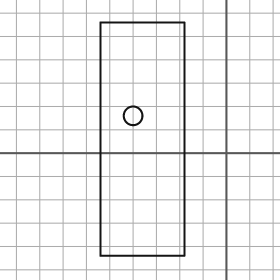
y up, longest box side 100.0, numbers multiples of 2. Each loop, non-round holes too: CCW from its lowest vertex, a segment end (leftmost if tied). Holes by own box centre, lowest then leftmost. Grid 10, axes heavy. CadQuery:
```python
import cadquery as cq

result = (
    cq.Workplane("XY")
    .moveTo(-54.0, -44.0)
    .lineTo(-18.0, -44.0)
    .lineTo(-18.0, 56.0)
    .lineTo(-54.0, 56.0)
    .close()
    .moveTo(-40.0, 16.0)
    .circle(4.0)
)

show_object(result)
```